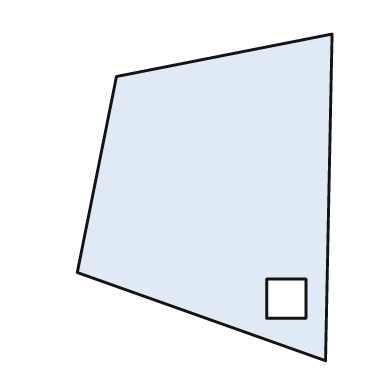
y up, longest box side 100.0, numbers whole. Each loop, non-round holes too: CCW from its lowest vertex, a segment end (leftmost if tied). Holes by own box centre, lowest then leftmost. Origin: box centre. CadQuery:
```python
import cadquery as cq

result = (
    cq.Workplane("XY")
    .moveTo(37.0, -50.0)
    .lineTo(39.0, 50.0)
    .lineTo(-27.0, 37.0)
    .lineTo(-39.0, -23.0)
    .close()
    .moveTo(19.0, -37.0)
    .lineTo(31.0, -37.0)
    .lineTo(31.0, -25.0)
    .lineTo(19.0, -25.0)
    .close()
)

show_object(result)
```